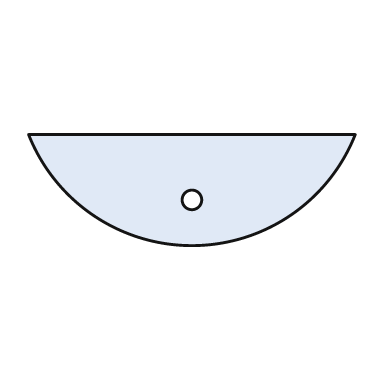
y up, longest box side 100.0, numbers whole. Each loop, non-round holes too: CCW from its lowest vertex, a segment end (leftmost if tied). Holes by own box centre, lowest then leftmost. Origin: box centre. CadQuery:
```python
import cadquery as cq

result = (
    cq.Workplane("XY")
    .moveTo(-50.0, 17.0)
    .threePointArc((0.0, -17.0), (50.0, 17.0))
    .close()
    .moveTo(0.0, -3.0)
    .circle(3.0)
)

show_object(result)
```